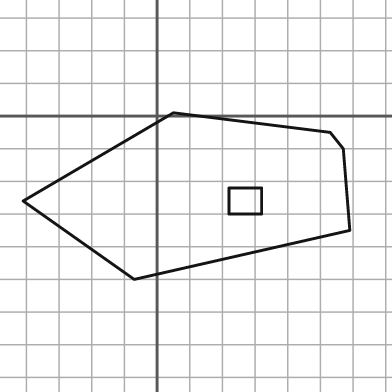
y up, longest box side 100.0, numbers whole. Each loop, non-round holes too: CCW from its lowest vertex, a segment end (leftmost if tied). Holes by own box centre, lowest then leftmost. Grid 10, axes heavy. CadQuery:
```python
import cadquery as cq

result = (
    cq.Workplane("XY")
    .moveTo(-7.0, -50.0)
    .lineTo(59.0, -35.0)
    .lineTo(57.0, -10.0)
    .lineTo(53.0, -5.0)
    .lineTo(5.0, 1.0)
    .lineTo(-41.0, -26.0)
    .close()
    .moveTo(22.0, -30.0)
    .lineTo(32.0, -30.0)
    .lineTo(32.0, -22.0)
    .lineTo(22.0, -22.0)
    .close()
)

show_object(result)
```